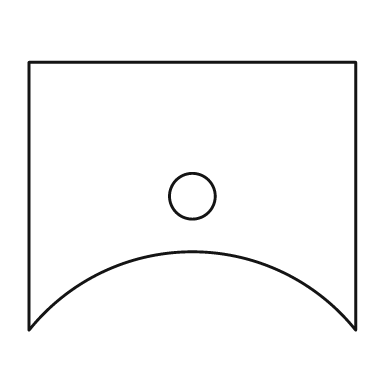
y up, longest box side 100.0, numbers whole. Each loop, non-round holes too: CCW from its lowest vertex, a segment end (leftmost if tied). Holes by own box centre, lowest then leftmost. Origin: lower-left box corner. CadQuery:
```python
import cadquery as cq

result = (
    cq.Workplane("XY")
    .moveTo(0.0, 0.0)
    .threePointArc((50.0, 24.0), (100.0, 0.0))
    .lineTo(100.0, 82.0)
    .lineTo(0.0, 82.0)
    .close()
    .moveTo(50.0, 41.0)
    .circle(7.0)
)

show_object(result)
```